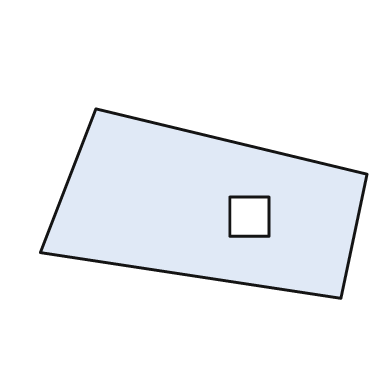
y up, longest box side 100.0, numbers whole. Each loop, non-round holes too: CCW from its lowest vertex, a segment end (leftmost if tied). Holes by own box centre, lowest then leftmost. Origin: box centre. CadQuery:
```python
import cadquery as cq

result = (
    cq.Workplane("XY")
    .moveTo(42.0, -29.0)
    .lineTo(50.0, 9.0)
    .lineTo(-33.0, 29.0)
    .lineTo(-50.0, -15.0)
    .close()
    .moveTo(8.0, -10.0)
    .lineTo(20.0, -10.0)
    .lineTo(20.0, 2.0)
    .lineTo(8.0, 2.0)
    .close()
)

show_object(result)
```